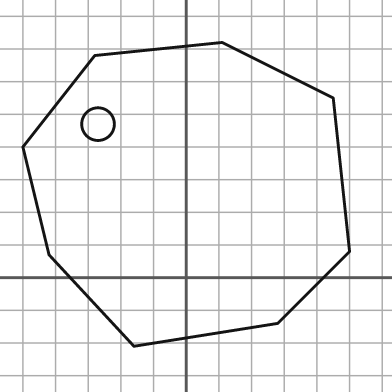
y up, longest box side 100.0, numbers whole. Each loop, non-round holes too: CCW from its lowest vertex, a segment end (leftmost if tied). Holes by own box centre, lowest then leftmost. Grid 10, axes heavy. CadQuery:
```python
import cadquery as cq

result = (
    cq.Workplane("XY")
    .moveTo(-16.0, -21.0)
    .lineTo(28.0, -14.0)
    .lineTo(50.0, 8.0)
    .lineTo(45.0, 55.0)
    .lineTo(11.0, 72.0)
    .lineTo(-28.0, 68.0)
    .lineTo(-50.0, 40.0)
    .lineTo(-42.0, 7.0)
    .close()
    .moveTo(-27.0, 47.0)
    .circle(5.0)
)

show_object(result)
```